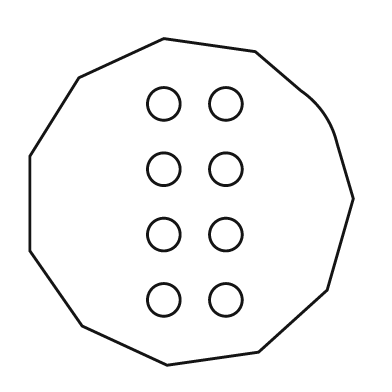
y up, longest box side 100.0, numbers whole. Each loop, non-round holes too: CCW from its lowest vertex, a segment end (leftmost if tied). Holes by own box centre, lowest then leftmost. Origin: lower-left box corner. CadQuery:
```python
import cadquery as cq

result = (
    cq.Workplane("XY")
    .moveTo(42.0, 0.0)
    .lineTo(70.0, 4.0)
    .lineTo(91.0, 23.0)
    .lineTo(99.0, 51.0)
    .lineTo(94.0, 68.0)
    .threePointArc((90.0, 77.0), (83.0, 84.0))
    .lineTo(69.0, 96.0)
    .lineTo(41.0, 100.0)
    .lineTo(15.0, 88.0)
    .lineTo(0.0, 64.0)
    .lineTo(0.0, 35.0)
    .lineTo(16.0, 12.0)
    .close()
    .moveTo(41.0, 20.0)
    .circle(5.0)
    .moveTo(60.0, 20.0)
    .circle(5.0)
    .moveTo(41.0, 40.0)
    .circle(5.0)
    .moveTo(60.0, 40.0)
    .circle(5.0)
    .moveTo(41.0, 60.0)
    .circle(5.0)
    .moveTo(60.0, 60.0)
    .circle(5.0)
    .moveTo(41.0, 80.0)
    .circle(5.0)
    .moveTo(60.0, 80.0)
    .circle(5.0)
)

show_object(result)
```